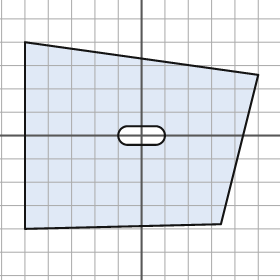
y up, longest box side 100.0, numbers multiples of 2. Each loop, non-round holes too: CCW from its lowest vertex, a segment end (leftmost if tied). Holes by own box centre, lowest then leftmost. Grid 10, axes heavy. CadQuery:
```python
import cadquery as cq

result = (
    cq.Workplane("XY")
    .moveTo(-50.0, -40.0)
    .lineTo(34.0, -38.0)
    .lineTo(50.0, 26.0)
    .lineTo(-50.0, 40.0)
    .close()
    .moveTo(-6.0, -4.0)
    .lineTo(6.0, -4.0)
    .threePointArc((10.0, 0.0), (6.0, 4.0))
    .lineTo(-6.0, 4.0)
    .threePointArc((-10.0, 0.0), (-6.0, -4.0))
    .close()
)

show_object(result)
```